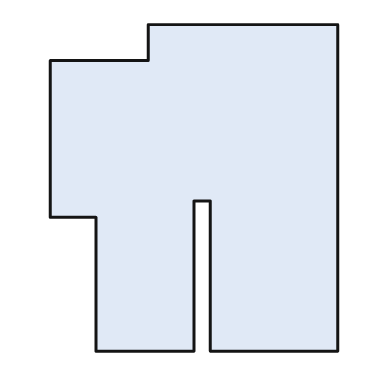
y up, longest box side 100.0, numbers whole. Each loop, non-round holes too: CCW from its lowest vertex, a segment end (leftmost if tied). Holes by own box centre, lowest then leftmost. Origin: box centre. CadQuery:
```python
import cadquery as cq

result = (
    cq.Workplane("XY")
    .moveTo(-30.0, -50.0)
    .lineTo(0.0, -50.0)
    .lineTo(0.0, -4.0)
    .lineTo(5.0, -4.0)
    .lineTo(5.0, -50.0)
    .lineTo(44.0, -50.0)
    .lineTo(44.0, 50.0)
    .lineTo(-14.0, 50.0)
    .lineTo(-14.0, 39.0)
    .lineTo(-44.0, 39.0)
    .lineTo(-44.0, -9.0)
    .lineTo(-30.0, -9.0)
    .close()
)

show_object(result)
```